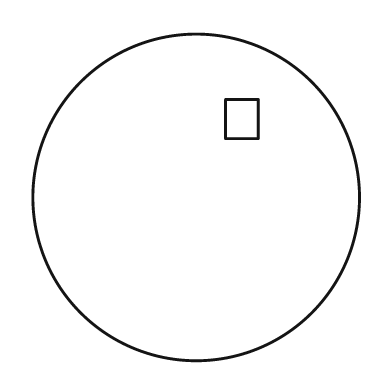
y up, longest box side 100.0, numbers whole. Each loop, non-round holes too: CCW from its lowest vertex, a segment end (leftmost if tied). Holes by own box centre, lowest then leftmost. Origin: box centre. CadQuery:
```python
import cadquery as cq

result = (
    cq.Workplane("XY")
    .moveTo(0.0, 0.0)
    .circle(50.0)
    .moveTo(9.0, 18.0)
    .lineTo(19.0, 18.0)
    .lineTo(19.0, 30.0)
    .lineTo(9.0, 30.0)
    .close()
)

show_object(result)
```